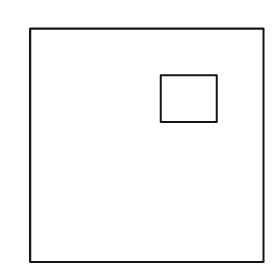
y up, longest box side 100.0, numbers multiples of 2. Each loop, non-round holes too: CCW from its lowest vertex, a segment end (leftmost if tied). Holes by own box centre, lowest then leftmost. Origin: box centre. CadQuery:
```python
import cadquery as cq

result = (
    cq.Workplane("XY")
    .moveTo(-50.0, -50.0)
    .lineTo(50.0, -50.0)
    .lineTo(50.0, 50.0)
    .lineTo(-50.0, 50.0)
    .close()
    .moveTo(6.0, 10.0)
    .lineTo(30.0, 10.0)
    .lineTo(30.0, 30.0)
    .lineTo(6.0, 30.0)
    .close()
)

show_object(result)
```